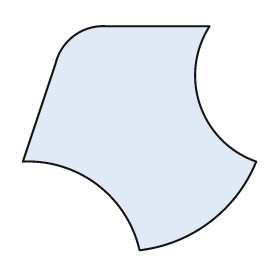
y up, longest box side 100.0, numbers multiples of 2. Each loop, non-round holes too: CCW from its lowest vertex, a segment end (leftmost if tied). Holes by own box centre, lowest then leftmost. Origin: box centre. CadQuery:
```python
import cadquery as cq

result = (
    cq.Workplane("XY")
    .moveTo(0.0, -48.0)
    .threePointArc((30.0, -36.0), (50.0, -10.0))
    .threePointArc((26.0, 14.0), (30.0, 48.0))
    .lineTo(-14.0, 48.0)
    .threePointArc((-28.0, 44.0), (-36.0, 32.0))
    .lineTo(-50.0, -10.0)
    .threePointArc((-18.0, -20.0), (0.0, -48.0))
    .close()
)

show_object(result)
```